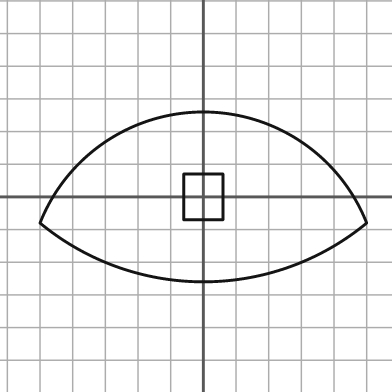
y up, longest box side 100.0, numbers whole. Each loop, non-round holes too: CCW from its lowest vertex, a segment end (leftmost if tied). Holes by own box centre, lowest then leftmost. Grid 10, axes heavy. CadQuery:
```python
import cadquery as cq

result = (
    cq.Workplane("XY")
    .moveTo(-50.0, -8.0)
    .threePointArc((0.0, -26.0), (50.0, -8.0))
    .threePointArc((0.0, 26.0), (-50.0, -8.0))
    .close()
    .moveTo(-6.0, -7.0)
    .lineTo(6.0, -7.0)
    .lineTo(6.0, 7.0)
    .lineTo(-6.0, 7.0)
    .close()
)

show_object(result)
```